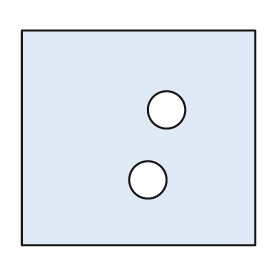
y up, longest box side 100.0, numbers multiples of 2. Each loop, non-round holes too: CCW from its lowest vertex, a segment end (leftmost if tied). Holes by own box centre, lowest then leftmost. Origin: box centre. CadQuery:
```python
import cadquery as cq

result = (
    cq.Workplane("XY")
    .moveTo(-50.0, -46.0)
    .lineTo(50.0, -46.0)
    .lineTo(50.0, 46.0)
    .lineTo(-50.0, 46.0)
    .close()
    .moveTo(4.0, -18.0)
    .circle(8.0)
    .moveTo(12.0, 12.0)
    .circle(8.0)
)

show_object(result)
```